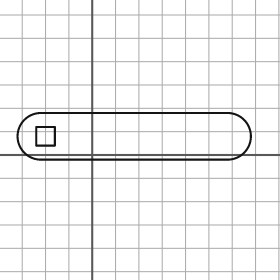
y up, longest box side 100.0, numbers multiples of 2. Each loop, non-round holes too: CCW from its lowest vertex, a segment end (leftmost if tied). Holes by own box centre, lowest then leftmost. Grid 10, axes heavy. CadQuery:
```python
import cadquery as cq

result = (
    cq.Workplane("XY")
    .moveTo(-22.0, -2.0)
    .lineTo(58.0, -2.0)
    .threePointArc((68.0, 8.0), (58.0, 18.0))
    .lineTo(-22.0, 18.0)
    .threePointArc((-32.0, 8.0), (-22.0, -2.0))
    .close()
    .moveTo(-24.0, 4.0)
    .lineTo(-16.0, 4.0)
    .lineTo(-16.0, 12.0)
    .lineTo(-24.0, 12.0)
    .close()
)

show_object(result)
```